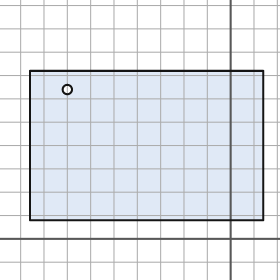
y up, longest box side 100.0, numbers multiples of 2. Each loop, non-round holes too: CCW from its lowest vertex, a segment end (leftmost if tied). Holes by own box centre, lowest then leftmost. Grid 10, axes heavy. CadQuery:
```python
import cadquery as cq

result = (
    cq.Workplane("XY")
    .moveTo(-86.0, 8.0)
    .lineTo(14.0, 8.0)
    .lineTo(14.0, 72.0)
    .lineTo(-86.0, 72.0)
    .close()
    .moveTo(-70.0, 64.0)
    .circle(2.0)
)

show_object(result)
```